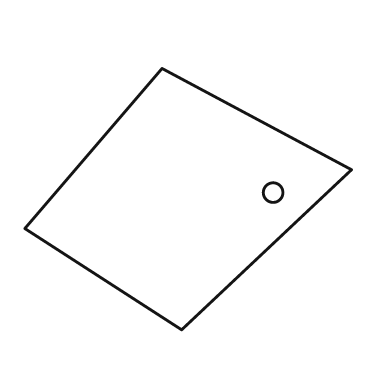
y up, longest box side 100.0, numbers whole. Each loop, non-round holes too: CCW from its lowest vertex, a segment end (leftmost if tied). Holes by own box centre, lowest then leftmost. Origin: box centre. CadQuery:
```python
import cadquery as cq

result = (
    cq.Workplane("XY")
    .moveTo(-2.0, -40.0)
    .lineTo(50.0, 9.0)
    .lineTo(-8.0, 40.0)
    .lineTo(-50.0, -9.0)
    .close()
    .moveTo(26.0, 2.0)
    .circle(3.0)
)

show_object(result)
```